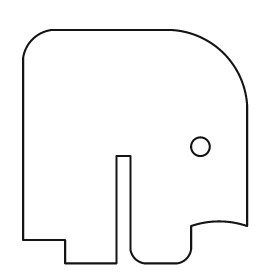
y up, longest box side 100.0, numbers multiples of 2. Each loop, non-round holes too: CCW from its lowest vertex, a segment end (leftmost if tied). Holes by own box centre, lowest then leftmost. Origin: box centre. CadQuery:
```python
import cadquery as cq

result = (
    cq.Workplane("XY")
    .moveTo(-30.0, -50.0)
    .lineTo(-8.0, -50.0)
    .lineTo(-8.0, -4.0)
    .lineTo(-2.0, -4.0)
    .lineTo(-2.0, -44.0)
    .threePointArc((0.0, -48.0), (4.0, -50.0))
    .lineTo(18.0, -50.0)
    .threePointArc((22.0, -48.0), (24.0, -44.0))
    .lineTo(24.0, -34.0)
    .threePointArc((36.0, -32.0), (48.0, -34.0))
    .lineTo(48.0, 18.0)
    .threePointArc((38.0, 40.0), (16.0, 50.0))
    .lineTo(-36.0, 50.0)
    .threePointArc((-44.0, 46.0), (-48.0, 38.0))
    .lineTo(-48.0, -40.0)
    .lineTo(-30.0, -40.0)
    .close()
    .moveTo(28.0, 0.0)
    .circle(4.0)
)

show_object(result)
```